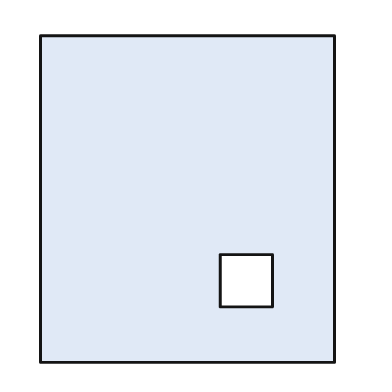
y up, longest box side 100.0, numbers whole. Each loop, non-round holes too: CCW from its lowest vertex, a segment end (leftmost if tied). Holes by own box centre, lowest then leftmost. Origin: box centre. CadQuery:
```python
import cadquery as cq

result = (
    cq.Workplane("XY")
    .moveTo(-45.0, -50.0)
    .lineTo(45.0, -50.0)
    .lineTo(45.0, 50.0)
    .lineTo(-45.0, 50.0)
    .close()
    .moveTo(10.0, -33.0)
    .lineTo(26.0, -33.0)
    .lineTo(26.0, -17.0)
    .lineTo(10.0, -17.0)
    .close()
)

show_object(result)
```